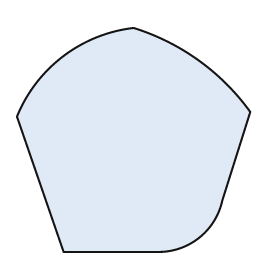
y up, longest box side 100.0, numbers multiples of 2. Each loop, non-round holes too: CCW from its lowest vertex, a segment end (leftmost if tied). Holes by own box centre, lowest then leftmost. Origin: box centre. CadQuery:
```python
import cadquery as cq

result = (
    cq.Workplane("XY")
    .moveTo(-30.0, -48.0)
    .lineTo(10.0, -48.0)
    .threePointArc((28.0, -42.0), (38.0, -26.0))
    .lineTo(50.0, 12.0)
    .threePointArc((28.0, 34.0), (0.0, 48.0))
    .threePointArc((-30.0, 36.0), (-50.0, 10.0))
    .close()
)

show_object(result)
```